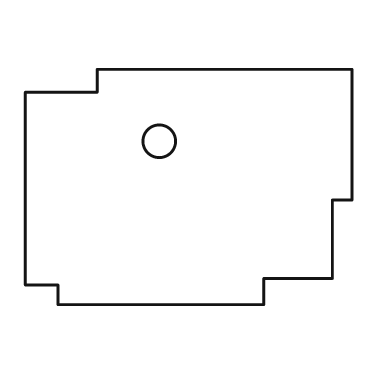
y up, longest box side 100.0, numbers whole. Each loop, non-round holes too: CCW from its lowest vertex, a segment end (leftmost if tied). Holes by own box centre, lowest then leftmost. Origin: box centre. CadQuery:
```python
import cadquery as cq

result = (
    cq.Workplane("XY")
    .moveTo(-40.0, -36.0)
    .lineTo(23.0, -36.0)
    .lineTo(23.0, -28.0)
    .lineTo(44.0, -28.0)
    .lineTo(44.0, -4.0)
    .lineTo(50.0, -4.0)
    .lineTo(50.0, 36.0)
    .lineTo(-28.0, 36.0)
    .lineTo(-28.0, 29.0)
    .lineTo(-50.0, 29.0)
    .lineTo(-50.0, -30.0)
    .lineTo(-40.0, -30.0)
    .close()
    .moveTo(-9.0, 14.0)
    .circle(5.0)
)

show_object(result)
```